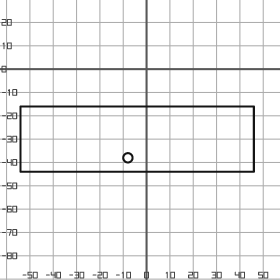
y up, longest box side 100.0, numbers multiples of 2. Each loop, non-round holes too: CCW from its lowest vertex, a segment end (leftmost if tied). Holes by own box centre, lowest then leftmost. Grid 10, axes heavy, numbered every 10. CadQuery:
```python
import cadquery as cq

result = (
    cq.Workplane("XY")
    .moveTo(-54.0, -44.0)
    .lineTo(46.0, -44.0)
    .lineTo(46.0, -16.0)
    .lineTo(-54.0, -16.0)
    .close()
    .moveTo(-8.0, -38.0)
    .circle(2.0)
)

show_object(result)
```